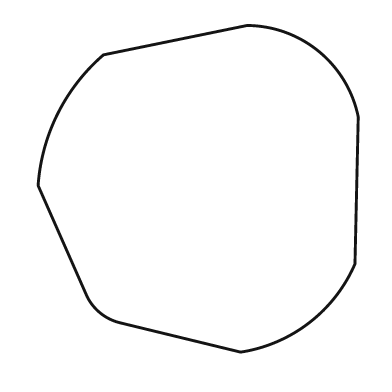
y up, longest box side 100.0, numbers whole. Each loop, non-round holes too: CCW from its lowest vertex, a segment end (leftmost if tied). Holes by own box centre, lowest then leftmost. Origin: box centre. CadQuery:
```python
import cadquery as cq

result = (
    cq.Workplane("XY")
    .moveTo(13.0, -50.0)
    .threePointArc((34.0, -41.0), (48.0, -23.0))
    .lineTo(49.0, 22.0)
    .threePointArc((37.0, 42.0), (15.0, 50.0))
    .lineTo(-29.0, 41.0)
    .threePointArc((-43.0, 23.0), (-49.0, 1.0))
    .lineTo(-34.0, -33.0)
    .threePointArc((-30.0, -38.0), (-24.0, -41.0))
    .close()
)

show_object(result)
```